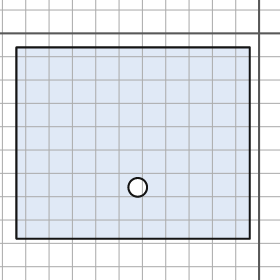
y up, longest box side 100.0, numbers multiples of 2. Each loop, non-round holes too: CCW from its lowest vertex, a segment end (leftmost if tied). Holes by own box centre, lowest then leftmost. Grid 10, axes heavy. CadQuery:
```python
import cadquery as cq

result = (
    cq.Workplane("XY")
    .moveTo(-104.0, -88.0)
    .lineTo(-4.0, -88.0)
    .lineTo(-4.0, -6.0)
    .lineTo(-104.0, -6.0)
    .close()
    .moveTo(-52.0, -66.0)
    .circle(4.0)
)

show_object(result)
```